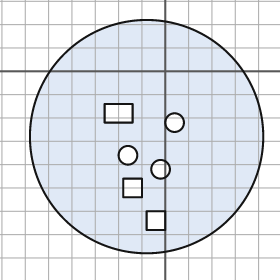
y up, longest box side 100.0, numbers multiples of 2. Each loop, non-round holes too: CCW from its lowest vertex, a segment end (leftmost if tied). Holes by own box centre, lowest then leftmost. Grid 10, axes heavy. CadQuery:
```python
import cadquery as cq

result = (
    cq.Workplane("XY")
    .moveTo(-8.0, -28.0)
    .circle(50.0)
    .moveTo(-8.0, -68.0)
    .lineTo(0.0, -68.0)
    .lineTo(0.0, -60.0)
    .lineTo(-8.0, -60.0)
    .close()
    .moveTo(-18.0, -54.0)
    .lineTo(-10.0, -54.0)
    .lineTo(-10.0, -46.0)
    .lineTo(-18.0, -46.0)
    .close()
    .moveTo(-2.0, -42.0)
    .circle(4.0)
    .moveTo(-16.0, -36.0)
    .circle(4.0)
    .moveTo(4.0, -22.0)
    .circle(4.0)
    .moveTo(-26.0, -22.0)
    .lineTo(-14.0, -22.0)
    .lineTo(-14.0, -14.0)
    .lineTo(-26.0, -14.0)
    .close()
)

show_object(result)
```